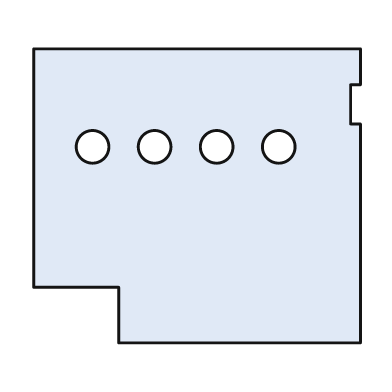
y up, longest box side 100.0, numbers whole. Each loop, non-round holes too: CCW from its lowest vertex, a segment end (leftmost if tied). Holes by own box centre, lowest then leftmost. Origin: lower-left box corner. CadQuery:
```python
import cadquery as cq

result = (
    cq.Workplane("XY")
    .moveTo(26.0, 0.0)
    .lineTo(100.0, 0.0)
    .lineTo(100.0, 67.0)
    .lineTo(97.0, 67.0)
    .lineTo(97.0, 79.0)
    .lineTo(100.0, 79.0)
    .lineTo(100.0, 90.0)
    .lineTo(0.0, 90.0)
    .lineTo(0.0, 17.0)
    .lineTo(26.0, 17.0)
    .close()
    .moveTo(18.0, 60.0)
    .circle(5.0)
    .moveTo(37.0, 60.0)
    .circle(5.0)
    .moveTo(56.0, 60.0)
    .circle(5.0)
    .moveTo(75.0, 60.0)
    .circle(5.0)
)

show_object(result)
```